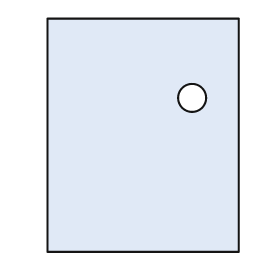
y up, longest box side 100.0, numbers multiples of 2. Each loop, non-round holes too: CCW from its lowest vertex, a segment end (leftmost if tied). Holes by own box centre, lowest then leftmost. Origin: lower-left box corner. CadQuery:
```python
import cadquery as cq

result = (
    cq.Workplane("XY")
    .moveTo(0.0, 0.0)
    .lineTo(82.0, 0.0)
    .lineTo(82.0, 100.0)
    .lineTo(0.0, 100.0)
    .close()
    .moveTo(62.0, 66.0)
    .circle(6.0)
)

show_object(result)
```